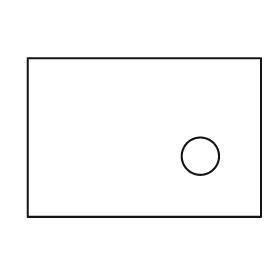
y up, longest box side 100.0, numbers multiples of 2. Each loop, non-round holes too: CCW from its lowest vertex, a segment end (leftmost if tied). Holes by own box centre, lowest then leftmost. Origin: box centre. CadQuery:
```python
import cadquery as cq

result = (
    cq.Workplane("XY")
    .moveTo(-50.0, -34.0)
    .lineTo(50.0, -34.0)
    .lineTo(50.0, 34.0)
    .lineTo(-50.0, 34.0)
    .close()
    .moveTo(24.0, -8.0)
    .circle(8.0)
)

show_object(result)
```